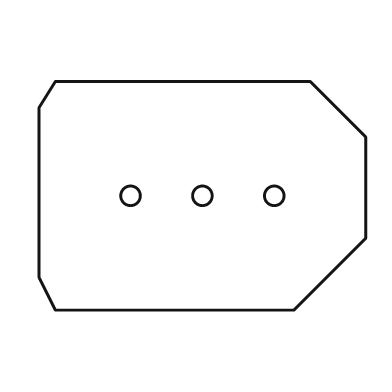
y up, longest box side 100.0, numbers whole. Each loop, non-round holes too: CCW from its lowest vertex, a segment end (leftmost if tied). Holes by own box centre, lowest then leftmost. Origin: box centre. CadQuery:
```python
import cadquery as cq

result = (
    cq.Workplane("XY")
    .moveTo(-45.0, -35.0)
    .lineTo(28.0, -35.0)
    .lineTo(50.0, -13.0)
    .lineTo(50.0, 18.0)
    .lineTo(33.0, 35.0)
    .lineTo(-45.0, 35.0)
    .lineTo(-50.0, 27.0)
    .lineTo(-50.0, -25.0)
    .close()
    .moveTo(-22.0, 0.0)
    .circle(3.0)
    .moveTo(0.0, 0.0)
    .circle(3.0)
    .moveTo(22.0, 0.0)
    .circle(3.0)
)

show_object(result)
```